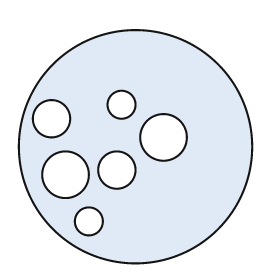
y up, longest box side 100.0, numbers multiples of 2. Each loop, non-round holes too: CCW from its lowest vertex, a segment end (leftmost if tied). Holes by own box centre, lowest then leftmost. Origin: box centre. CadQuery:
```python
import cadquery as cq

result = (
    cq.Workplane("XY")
    .moveTo(0.0, 0.0)
    .circle(50.0)
    .moveTo(-20.0, -32.0)
    .circle(6.0)
    .moveTo(-30.0, -12.0)
    .circle(10.0)
    .moveTo(-8.0, -10.0)
    .circle(8.0)
    .moveTo(12.0, 4.0)
    .circle(10.0)
    .moveTo(-36.0, 12.0)
    .circle(8.0)
    .moveTo(-6.0, 18.0)
    .circle(6.0)
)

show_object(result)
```